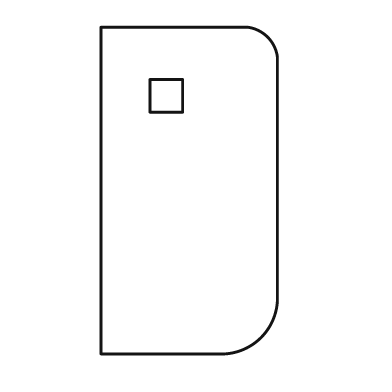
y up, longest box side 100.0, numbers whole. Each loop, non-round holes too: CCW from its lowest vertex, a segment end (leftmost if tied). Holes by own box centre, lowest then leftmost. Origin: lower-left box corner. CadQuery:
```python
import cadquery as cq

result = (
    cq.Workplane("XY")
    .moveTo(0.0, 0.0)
    .lineTo(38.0, 0.0)
    .threePointArc((49.0, 5.0), (54.0, 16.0))
    .lineTo(54.0, 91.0)
    .threePointArc((51.0, 97.0), (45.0, 100.0))
    .lineTo(0.0, 100.0)
    .close()
    .moveTo(15.0, 74.0)
    .lineTo(25.0, 74.0)
    .lineTo(25.0, 84.0)
    .lineTo(15.0, 84.0)
    .close()
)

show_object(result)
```